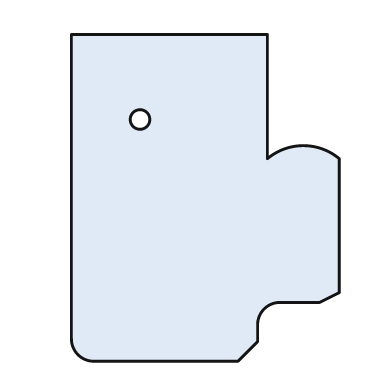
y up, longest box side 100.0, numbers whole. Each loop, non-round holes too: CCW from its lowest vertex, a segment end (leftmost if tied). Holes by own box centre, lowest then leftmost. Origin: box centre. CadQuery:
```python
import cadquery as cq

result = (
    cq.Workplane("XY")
    .moveTo(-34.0, -50.0)
    .lineTo(10.0, -50.0)
    .lineTo(16.0, -44.0)
    .lineTo(16.0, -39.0)
    .threePointArc((18.0, -34.0), (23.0, -32.0))
    .lineTo(35.0, -32.0)
    .lineTo(41.0, -29.0)
    .lineTo(41.0, 12.0)
    .threePointArc((30.0, 16.0), (19.0, 12.0))
    .lineTo(19.0, 50.0)
    .lineTo(-41.0, 50.0)
    .lineTo(-41.0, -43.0)
    .threePointArc((-39.0, -48.0), (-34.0, -50.0))
    .close()
    .moveTo(-20.0, 24.0)
    .circle(3.0)
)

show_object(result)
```